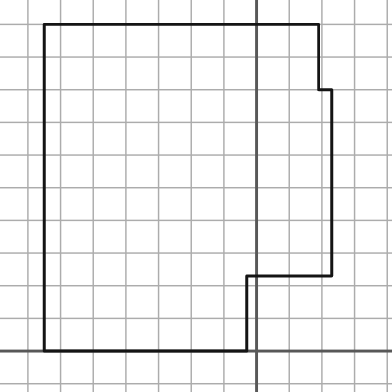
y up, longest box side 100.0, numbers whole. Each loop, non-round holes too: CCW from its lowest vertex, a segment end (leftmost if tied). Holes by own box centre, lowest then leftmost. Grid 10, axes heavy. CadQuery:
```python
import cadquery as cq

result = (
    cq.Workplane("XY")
    .moveTo(-65.0, 0.0)
    .lineTo(-3.0, 0.0)
    .lineTo(-3.0, 23.0)
    .lineTo(23.0, 23.0)
    .lineTo(23.0, 80.0)
    .lineTo(19.0, 80.0)
    .lineTo(19.0, 100.0)
    .lineTo(-65.0, 100.0)
    .close()
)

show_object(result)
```